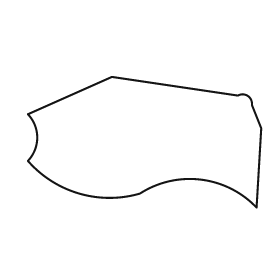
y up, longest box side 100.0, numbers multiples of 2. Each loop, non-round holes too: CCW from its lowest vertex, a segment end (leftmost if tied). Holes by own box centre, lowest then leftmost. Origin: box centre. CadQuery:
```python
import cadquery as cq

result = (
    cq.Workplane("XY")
    .moveTo(48.0, -28.0)
    .lineTo(50.0, 6.0)
    .lineTo(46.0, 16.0)
    .threePointArc((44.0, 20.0), (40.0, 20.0))
    .lineTo(-14.0, 28.0)
    .lineTo(-50.0, 12.0)
    .threePointArc((-46.0, 2.0), (-50.0, -8.0))
    .threePointArc((-28.0, -22.0), (-2.0, -22.0))
    .threePointArc((24.0, -16.0), (48.0, -28.0))
    .close()
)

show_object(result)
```